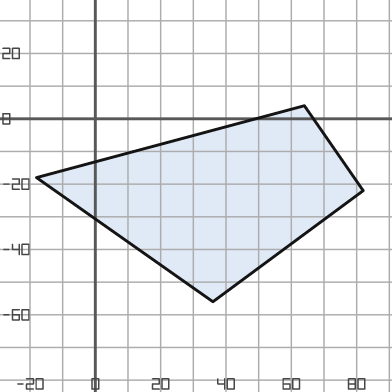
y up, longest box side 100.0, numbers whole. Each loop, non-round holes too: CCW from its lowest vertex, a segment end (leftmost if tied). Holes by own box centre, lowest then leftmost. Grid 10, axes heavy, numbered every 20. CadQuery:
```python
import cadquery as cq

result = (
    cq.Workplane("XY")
    .moveTo(36.0, -56.0)
    .lineTo(82.0, -22.0)
    .lineTo(64.0, 4.0)
    .lineTo(-18.0, -18.0)
    .close()
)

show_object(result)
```